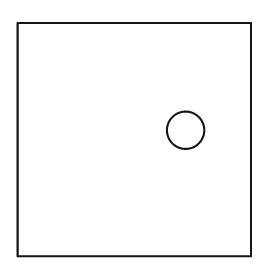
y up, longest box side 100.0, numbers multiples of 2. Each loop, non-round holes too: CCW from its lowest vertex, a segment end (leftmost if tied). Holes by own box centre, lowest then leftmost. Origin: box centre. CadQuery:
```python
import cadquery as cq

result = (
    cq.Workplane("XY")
    .moveTo(-50.0, -50.0)
    .lineTo(50.0, -50.0)
    .lineTo(50.0, 50.0)
    .lineTo(-50.0, 50.0)
    .close()
    .moveTo(22.0, 4.0)
    .circle(8.0)
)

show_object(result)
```